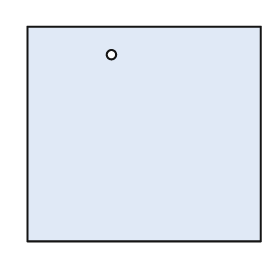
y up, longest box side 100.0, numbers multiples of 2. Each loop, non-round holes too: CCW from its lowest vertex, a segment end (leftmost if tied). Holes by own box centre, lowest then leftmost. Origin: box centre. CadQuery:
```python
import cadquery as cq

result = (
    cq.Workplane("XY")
    .moveTo(-50.0, -46.0)
    .lineTo(50.0, -46.0)
    .lineTo(50.0, 46.0)
    .lineTo(-50.0, 46.0)
    .close()
    .moveTo(-14.0, 34.0)
    .circle(2.0)
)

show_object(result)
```